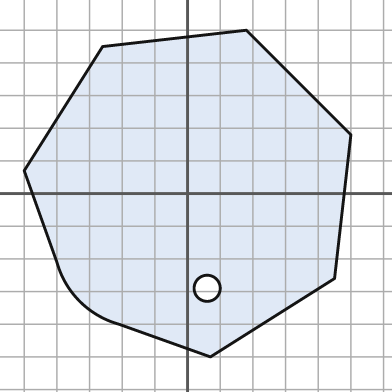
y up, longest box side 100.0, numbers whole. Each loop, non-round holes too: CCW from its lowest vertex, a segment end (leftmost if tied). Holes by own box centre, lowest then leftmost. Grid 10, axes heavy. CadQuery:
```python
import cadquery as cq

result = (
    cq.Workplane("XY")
    .moveTo(7.0, -50.0)
    .lineTo(45.0, -26.0)
    .lineTo(50.0, 18.0)
    .lineTo(18.0, 50.0)
    .lineTo(-26.0, 45.0)
    .lineTo(-50.0, 7.0)
    .lineTo(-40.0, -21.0)
    .threePointArc((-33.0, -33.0), (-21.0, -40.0))
    .close()
    .moveTo(6.0, -29.0)
    .circle(4.0)
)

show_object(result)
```